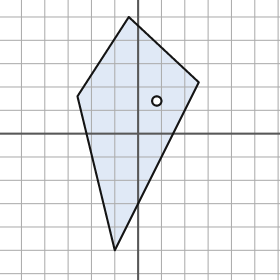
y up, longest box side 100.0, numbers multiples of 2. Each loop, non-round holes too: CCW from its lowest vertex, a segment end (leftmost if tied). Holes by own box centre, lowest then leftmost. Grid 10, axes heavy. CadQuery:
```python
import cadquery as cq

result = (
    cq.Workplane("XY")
    .moveTo(-10.0, -50.0)
    .lineTo(26.0, 22.0)
    .lineTo(-4.0, 50.0)
    .lineTo(-26.0, 16.0)
    .close()
    .moveTo(8.0, 14.0)
    .circle(2.0)
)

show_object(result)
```